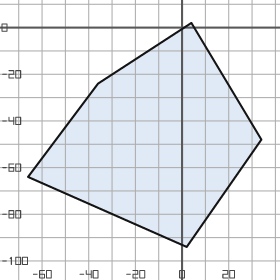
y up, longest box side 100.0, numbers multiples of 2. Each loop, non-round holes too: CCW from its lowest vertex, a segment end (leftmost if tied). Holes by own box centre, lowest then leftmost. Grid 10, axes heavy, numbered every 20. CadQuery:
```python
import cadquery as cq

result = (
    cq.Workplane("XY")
    .moveTo(2.0, -94.0)
    .lineTo(34.0, -48.0)
    .lineTo(4.0, 2.0)
    .lineTo(-36.0, -24.0)
    .lineTo(-66.0, -64.0)
    .close()
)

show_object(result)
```